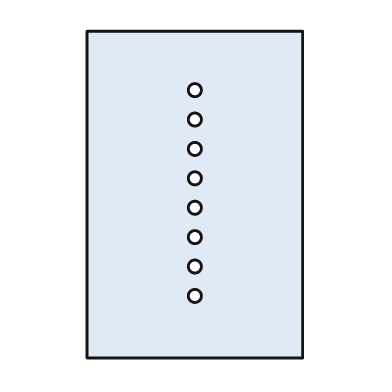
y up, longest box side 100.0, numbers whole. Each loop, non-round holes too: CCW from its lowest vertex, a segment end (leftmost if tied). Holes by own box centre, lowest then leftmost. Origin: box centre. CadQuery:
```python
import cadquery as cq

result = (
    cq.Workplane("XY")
    .moveTo(-33.0, -50.0)
    .lineTo(33.0, -50.0)
    .lineTo(33.0, 50.0)
    .lineTo(-33.0, 50.0)
    .close()
    .moveTo(0.0, -31.0)
    .circle(2.0)
    .moveTo(0.0, -22.0)
    .circle(2.0)
    .moveTo(0.0, -13.0)
    .circle(2.0)
    .moveTo(0.0, -4.0)
    .circle(2.0)
    .moveTo(0.0, 5.0)
    .circle(2.0)
    .moveTo(0.0, 14.0)
    .circle(2.0)
    .moveTo(0.0, 23.0)
    .circle(2.0)
    .moveTo(0.0, 32.0)
    .circle(2.0)
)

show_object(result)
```